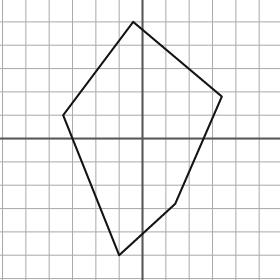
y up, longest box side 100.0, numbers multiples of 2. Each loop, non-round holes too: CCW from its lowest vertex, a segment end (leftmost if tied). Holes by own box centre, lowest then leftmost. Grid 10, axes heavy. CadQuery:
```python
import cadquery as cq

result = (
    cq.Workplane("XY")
    .moveTo(-10.0, -50.0)
    .lineTo(14.0, -28.0)
    .lineTo(34.0, 18.0)
    .lineTo(-4.0, 50.0)
    .lineTo(-34.0, 10.0)
    .close()
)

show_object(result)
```